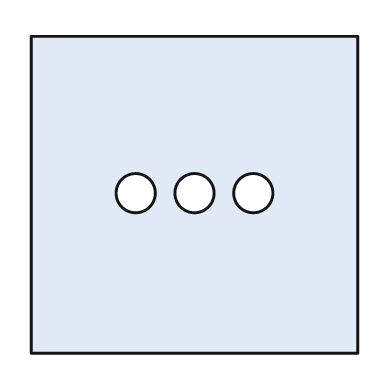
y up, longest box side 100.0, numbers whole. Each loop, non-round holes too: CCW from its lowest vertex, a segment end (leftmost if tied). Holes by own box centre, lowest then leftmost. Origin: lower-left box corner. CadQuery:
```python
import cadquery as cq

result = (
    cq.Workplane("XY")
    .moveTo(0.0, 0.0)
    .lineTo(100.0, 0.0)
    .lineTo(100.0, 97.0)
    .lineTo(0.0, 97.0)
    .close()
    .moveTo(32.0, 49.0)
    .circle(6.0)
    .moveTo(50.0, 49.0)
    .circle(6.0)
    .moveTo(68.0, 49.0)
    .circle(6.0)
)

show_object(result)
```